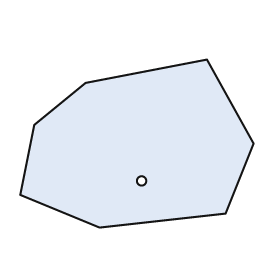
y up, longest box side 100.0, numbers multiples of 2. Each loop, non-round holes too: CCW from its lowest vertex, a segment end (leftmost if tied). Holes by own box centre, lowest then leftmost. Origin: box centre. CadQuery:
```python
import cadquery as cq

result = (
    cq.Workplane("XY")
    .moveTo(-16.0, -36.0)
    .lineTo(38.0, -30.0)
    .lineTo(50.0, 0.0)
    .lineTo(30.0, 36.0)
    .lineTo(-22.0, 26.0)
    .lineTo(-44.0, 8.0)
    .lineTo(-50.0, -22.0)
    .close()
    .moveTo(2.0, -16.0)
    .circle(2.0)
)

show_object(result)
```